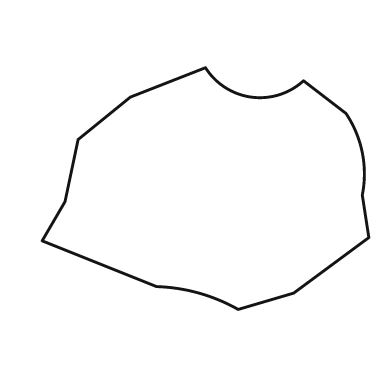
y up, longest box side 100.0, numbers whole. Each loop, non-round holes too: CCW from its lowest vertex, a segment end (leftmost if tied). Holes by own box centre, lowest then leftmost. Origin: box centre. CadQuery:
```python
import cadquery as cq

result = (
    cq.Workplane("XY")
    .moveTo(10.0, -37.0)
    .lineTo(27.0, -32.0)
    .lineTo(50.0, -15.0)
    .lineTo(48.0, -2.0)
    .threePointArc((48.0, 11.0), (43.0, 23.0))
    .lineTo(30.0, 33.0)
    .threePointArc((14.0, 28.0), (0.0, 37.0))
    .lineTo(-23.0, 28.0)
    .lineTo(-39.0, 15.0)
    .lineTo(-43.0, -4.0)
    .lineTo(-50.0, -16.0)
    .lineTo(-15.0, -30.0)
    .threePointArc((-2.0, -32.0), (10.0, -37.0))
    .close()
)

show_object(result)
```